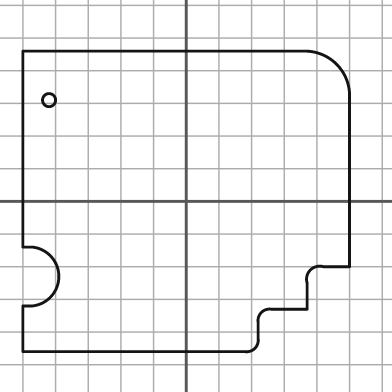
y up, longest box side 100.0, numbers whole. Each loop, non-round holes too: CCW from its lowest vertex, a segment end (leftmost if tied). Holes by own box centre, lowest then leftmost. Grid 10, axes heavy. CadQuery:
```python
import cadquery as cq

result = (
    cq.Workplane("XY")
    .moveTo(-50.0, -46.0)
    .lineTo(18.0, -46.0)
    .threePointArc((21.0, -45.0), (22.0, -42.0))
    .lineTo(22.0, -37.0)
    .threePointArc((23.0, -34.0), (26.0, -33.0))
    .lineTo(37.0, -33.0)
    .lineTo(37.0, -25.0)
    .threePointArc((38.0, -21.0), (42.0, -20.0))
    .lineTo(50.0, -20.0)
    .lineTo(50.0, 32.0)
    .threePointArc((46.0, 42.0), (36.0, 46.0))
    .lineTo(-50.0, 46.0)
    .lineTo(-50.0, -14.0)
    .lineTo(-47.0, -14.0)
    .threePointArc((-39.0, -23.0), (-47.0, -32.0))
    .lineTo(-50.0, -32.0)
    .close()
    .moveTo(-42.0, 31.0)
    .circle(2.0)
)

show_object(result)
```